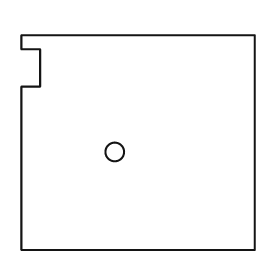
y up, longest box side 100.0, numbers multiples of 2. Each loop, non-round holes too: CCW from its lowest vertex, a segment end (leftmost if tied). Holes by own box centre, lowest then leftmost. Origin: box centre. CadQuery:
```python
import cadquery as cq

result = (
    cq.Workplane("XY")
    .moveTo(-50.0, -46.0)
    .lineTo(50.0, -46.0)
    .lineTo(50.0, 46.0)
    .lineTo(-50.0, 46.0)
    .lineTo(-50.0, 40.0)
    .lineTo(-42.0, 40.0)
    .lineTo(-42.0, 24.0)
    .lineTo(-50.0, 24.0)
    .close()
    .moveTo(-10.0, -4.0)
    .circle(4.0)
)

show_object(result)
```